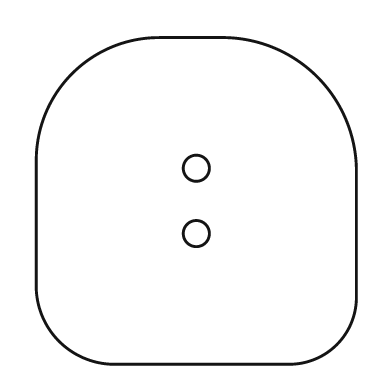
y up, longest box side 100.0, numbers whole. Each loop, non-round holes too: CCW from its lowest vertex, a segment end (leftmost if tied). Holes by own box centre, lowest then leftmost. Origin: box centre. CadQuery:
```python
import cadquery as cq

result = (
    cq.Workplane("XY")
    .moveTo(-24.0, -50.0)
    .lineTo(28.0, -50.0)
    .threePointArc((43.0, -44.0), (49.0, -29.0))
    .lineTo(49.0, 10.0)
    .threePointArc((37.0, 38.0), (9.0, 50.0))
    .lineTo(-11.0, 50.0)
    .threePointArc((-38.0, 39.0), (-49.0, 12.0))
    .lineTo(-49.0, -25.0)
    .threePointArc((-42.0, -43.0), (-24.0, -50.0))
    .close()
    .moveTo(0.0, -10.0)
    .circle(4.0)
    .moveTo(0.0, 10.0)
    .circle(4.0)
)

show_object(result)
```